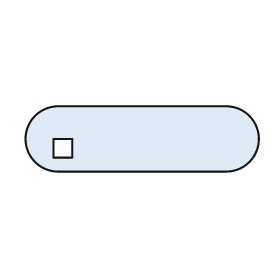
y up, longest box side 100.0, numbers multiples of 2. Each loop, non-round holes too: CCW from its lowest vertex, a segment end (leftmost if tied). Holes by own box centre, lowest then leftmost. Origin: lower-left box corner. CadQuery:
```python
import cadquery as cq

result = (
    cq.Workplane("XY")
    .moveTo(14.0, 0.0)
    .lineTo(86.0, 0.0)
    .threePointArc((100.0, 14.0), (86.0, 28.0))
    .lineTo(14.0, 28.0)
    .threePointArc((0.0, 14.0), (14.0, 0.0))
    .close()
    .moveTo(12.0, 6.0)
    .lineTo(20.0, 6.0)
    .lineTo(20.0, 14.0)
    .lineTo(12.0, 14.0)
    .close()
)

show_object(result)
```